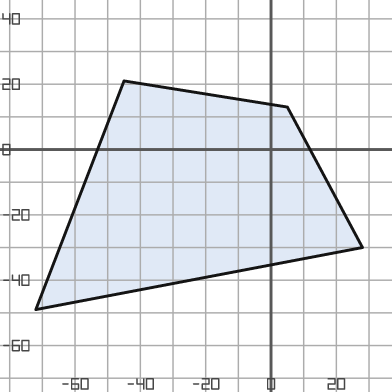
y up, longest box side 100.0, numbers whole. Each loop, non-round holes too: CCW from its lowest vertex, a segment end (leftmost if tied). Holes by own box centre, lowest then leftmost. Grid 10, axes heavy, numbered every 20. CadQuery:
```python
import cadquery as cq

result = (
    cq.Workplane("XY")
    .moveTo(-72.0, -49.0)
    .lineTo(28.0, -30.0)
    .lineTo(5.0, 13.0)
    .lineTo(-45.0, 21.0)
    .close()
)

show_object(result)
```